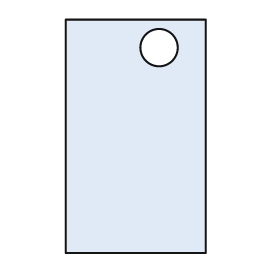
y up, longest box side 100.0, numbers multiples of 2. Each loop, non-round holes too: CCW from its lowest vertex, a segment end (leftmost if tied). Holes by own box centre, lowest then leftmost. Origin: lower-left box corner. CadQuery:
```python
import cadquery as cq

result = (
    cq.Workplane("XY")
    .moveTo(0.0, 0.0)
    .lineTo(60.0, 0.0)
    .lineTo(60.0, 100.0)
    .lineTo(0.0, 100.0)
    .close()
    .moveTo(40.0, 88.0)
    .circle(8.0)
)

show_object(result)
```